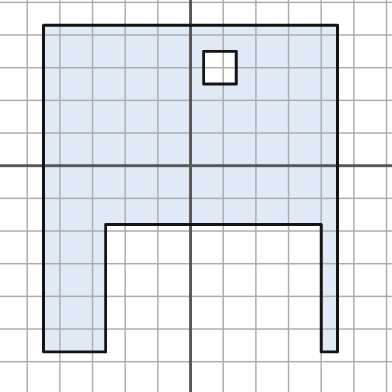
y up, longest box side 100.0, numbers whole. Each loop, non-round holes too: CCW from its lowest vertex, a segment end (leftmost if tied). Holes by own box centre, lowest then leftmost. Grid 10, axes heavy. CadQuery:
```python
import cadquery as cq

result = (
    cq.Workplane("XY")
    .moveTo(-45.0, -57.0)
    .lineTo(-26.0, -57.0)
    .lineTo(-26.0, -18.0)
    .lineTo(40.0, -18.0)
    .lineTo(40.0, -57.0)
    .lineTo(45.0, -57.0)
    .lineTo(45.0, 43.0)
    .lineTo(-45.0, 43.0)
    .close()
    .moveTo(4.0, 25.0)
    .lineTo(14.0, 25.0)
    .lineTo(14.0, 35.0)
    .lineTo(4.0, 35.0)
    .close()
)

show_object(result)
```